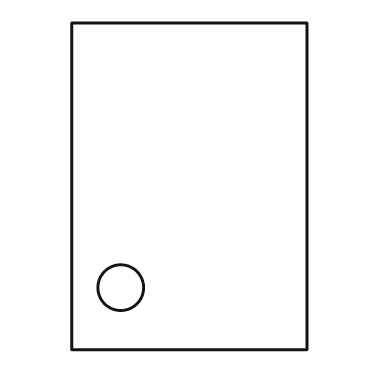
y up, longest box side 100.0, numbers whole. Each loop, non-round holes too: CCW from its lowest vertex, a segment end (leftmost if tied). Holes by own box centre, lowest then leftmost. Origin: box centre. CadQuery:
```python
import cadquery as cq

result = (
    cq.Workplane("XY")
    .moveTo(-36.0, -50.0)
    .lineTo(36.0, -50.0)
    .lineTo(36.0, 50.0)
    .lineTo(-36.0, 50.0)
    .close()
    .moveTo(-21.0, -31.0)
    .circle(7.0)
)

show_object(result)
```